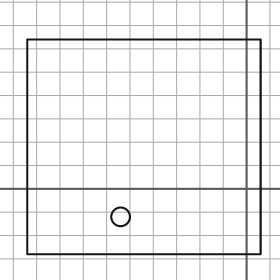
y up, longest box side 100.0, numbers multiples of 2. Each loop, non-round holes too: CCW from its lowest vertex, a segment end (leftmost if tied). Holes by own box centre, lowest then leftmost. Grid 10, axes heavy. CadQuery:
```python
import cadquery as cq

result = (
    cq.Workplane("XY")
    .moveTo(-94.0, -28.0)
    .lineTo(6.0, -28.0)
    .lineTo(6.0, 64.0)
    .lineTo(-94.0, 64.0)
    .close()
    .moveTo(-54.0, -12.0)
    .circle(4.0)
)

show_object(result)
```